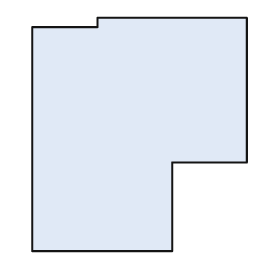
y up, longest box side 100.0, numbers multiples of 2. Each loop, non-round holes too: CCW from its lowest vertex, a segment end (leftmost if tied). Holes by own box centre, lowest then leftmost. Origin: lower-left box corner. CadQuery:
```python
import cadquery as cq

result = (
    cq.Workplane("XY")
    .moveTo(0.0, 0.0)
    .lineTo(60.0, 0.0)
    .lineTo(60.0, 38.0)
    .lineTo(92.0, 38.0)
    .lineTo(92.0, 100.0)
    .lineTo(28.0, 100.0)
    .lineTo(28.0, 96.0)
    .lineTo(0.0, 96.0)
    .close()
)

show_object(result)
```